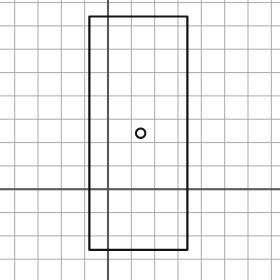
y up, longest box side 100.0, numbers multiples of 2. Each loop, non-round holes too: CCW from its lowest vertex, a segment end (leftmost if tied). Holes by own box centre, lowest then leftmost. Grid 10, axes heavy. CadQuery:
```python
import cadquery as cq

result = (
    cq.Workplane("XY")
    .moveTo(-8.0, -26.0)
    .lineTo(34.0, -26.0)
    .lineTo(34.0, 74.0)
    .lineTo(-8.0, 74.0)
    .close()
    .moveTo(14.0, 24.0)
    .circle(2.0)
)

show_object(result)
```